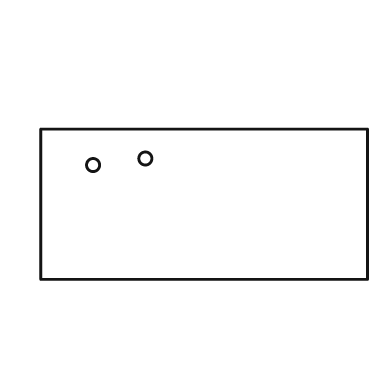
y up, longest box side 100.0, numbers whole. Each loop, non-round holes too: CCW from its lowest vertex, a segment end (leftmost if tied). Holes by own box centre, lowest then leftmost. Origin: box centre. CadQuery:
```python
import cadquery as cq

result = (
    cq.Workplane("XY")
    .moveTo(-50.0, -23.0)
    .lineTo(50.0, -23.0)
    .lineTo(50.0, 23.0)
    .lineTo(-50.0, 23.0)
    .close()
    .moveTo(-34.0, 12.0)
    .circle(2.0)
    .moveTo(-18.0, 14.0)
    .circle(2.0)
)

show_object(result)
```